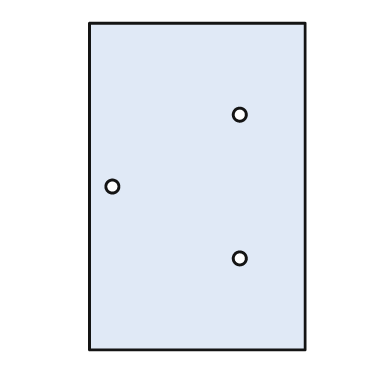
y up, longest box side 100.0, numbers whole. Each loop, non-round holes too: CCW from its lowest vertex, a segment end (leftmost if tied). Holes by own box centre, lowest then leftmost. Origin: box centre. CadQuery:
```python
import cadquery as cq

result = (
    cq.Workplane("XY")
    .moveTo(-33.0, -50.0)
    .lineTo(33.0, -50.0)
    .lineTo(33.0, 50.0)
    .lineTo(-33.0, 50.0)
    .close()
    .moveTo(13.0, -22.0)
    .circle(2.0)
    .moveTo(-26.0, 0.0)
    .circle(2.0)
    .moveTo(13.0, 22.0)
    .circle(2.0)
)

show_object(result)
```